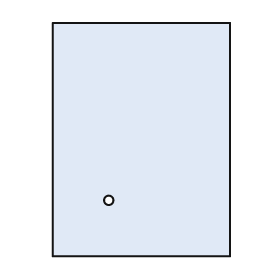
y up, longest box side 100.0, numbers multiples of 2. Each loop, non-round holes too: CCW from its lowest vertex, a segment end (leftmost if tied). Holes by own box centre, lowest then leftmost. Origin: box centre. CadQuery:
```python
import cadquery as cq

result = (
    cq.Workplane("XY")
    .moveTo(-38.0, -50.0)
    .lineTo(38.0, -50.0)
    .lineTo(38.0, 50.0)
    .lineTo(-38.0, 50.0)
    .close()
    .moveTo(-14.0, -26.0)
    .circle(2.0)
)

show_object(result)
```